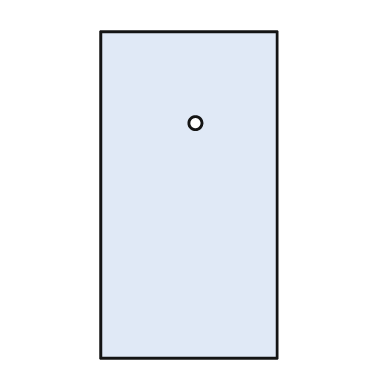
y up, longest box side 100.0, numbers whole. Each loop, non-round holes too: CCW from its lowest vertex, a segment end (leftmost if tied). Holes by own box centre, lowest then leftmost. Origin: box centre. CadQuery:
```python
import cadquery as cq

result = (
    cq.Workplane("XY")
    .moveTo(-27.0, -50.0)
    .lineTo(27.0, -50.0)
    .lineTo(27.0, 50.0)
    .lineTo(-27.0, 50.0)
    .close()
    .moveTo(2.0, 22.0)
    .circle(2.0)
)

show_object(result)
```